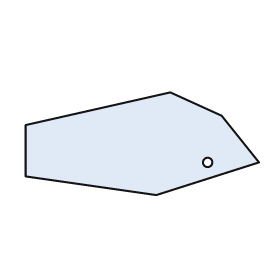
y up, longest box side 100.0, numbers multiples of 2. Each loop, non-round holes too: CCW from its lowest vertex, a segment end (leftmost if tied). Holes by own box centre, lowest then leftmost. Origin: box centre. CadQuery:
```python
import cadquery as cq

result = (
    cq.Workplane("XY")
    .moveTo(6.0, -22.0)
    .lineTo(50.0, -8.0)
    .lineTo(34.0, 12.0)
    .lineTo(12.0, 22.0)
    .lineTo(-50.0, 8.0)
    .lineTo(-50.0, -14.0)
    .close()
    .moveTo(28.0, -8.0)
    .circle(2.0)
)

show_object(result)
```